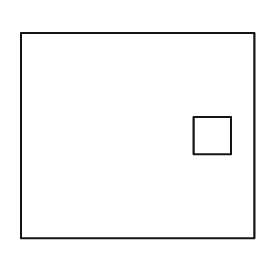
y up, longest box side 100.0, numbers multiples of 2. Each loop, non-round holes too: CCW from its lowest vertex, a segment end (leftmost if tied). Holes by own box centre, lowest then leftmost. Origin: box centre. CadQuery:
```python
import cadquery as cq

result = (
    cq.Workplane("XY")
    .moveTo(-50.0, -44.0)
    .lineTo(50.0, -44.0)
    .lineTo(50.0, 44.0)
    .lineTo(-50.0, 44.0)
    .close()
    .moveTo(24.0, -8.0)
    .lineTo(40.0, -8.0)
    .lineTo(40.0, 8.0)
    .lineTo(24.0, 8.0)
    .close()
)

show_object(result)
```